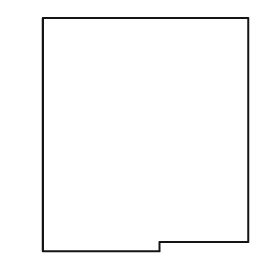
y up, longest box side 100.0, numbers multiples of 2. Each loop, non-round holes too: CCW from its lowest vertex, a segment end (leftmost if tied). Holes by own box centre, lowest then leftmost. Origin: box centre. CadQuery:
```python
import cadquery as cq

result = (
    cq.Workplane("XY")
    .moveTo(-44.0, -50.0)
    .lineTo(6.0, -50.0)
    .lineTo(6.0, -46.0)
    .lineTo(44.0, -46.0)
    .lineTo(44.0, 50.0)
    .lineTo(-44.0, 50.0)
    .close()
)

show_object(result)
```